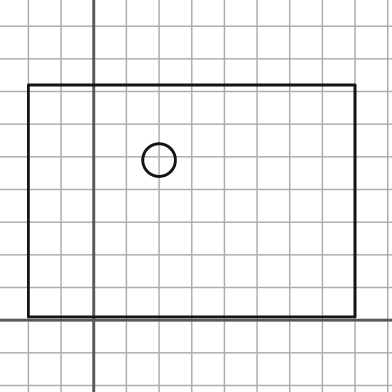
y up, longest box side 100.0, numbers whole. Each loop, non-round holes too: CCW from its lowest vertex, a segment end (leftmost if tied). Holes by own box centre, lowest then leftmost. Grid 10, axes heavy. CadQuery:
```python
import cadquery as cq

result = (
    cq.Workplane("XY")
    .moveTo(-20.0, 1.0)
    .lineTo(80.0, 1.0)
    .lineTo(80.0, 72.0)
    .lineTo(-20.0, 72.0)
    .close()
    .moveTo(20.0, 49.0)
    .circle(5.0)
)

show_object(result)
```